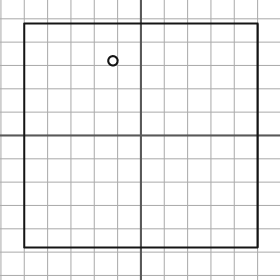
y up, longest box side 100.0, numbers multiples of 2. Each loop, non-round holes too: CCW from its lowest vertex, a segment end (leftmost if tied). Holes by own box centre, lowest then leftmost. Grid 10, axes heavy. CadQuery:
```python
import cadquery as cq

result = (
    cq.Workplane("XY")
    .moveTo(-50.0, -48.0)
    .lineTo(50.0, -48.0)
    .lineTo(50.0, 48.0)
    .lineTo(-50.0, 48.0)
    .close()
    .moveTo(-12.0, 32.0)
    .circle(2.0)
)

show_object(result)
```